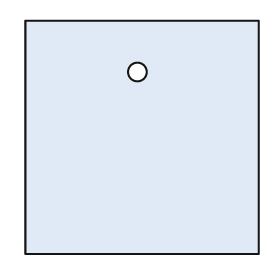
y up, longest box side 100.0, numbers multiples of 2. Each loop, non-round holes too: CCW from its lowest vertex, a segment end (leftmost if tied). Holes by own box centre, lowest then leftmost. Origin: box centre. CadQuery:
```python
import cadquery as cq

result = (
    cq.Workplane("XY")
    .moveTo(-50.0, -50.0)
    .lineTo(50.0, -50.0)
    .lineTo(50.0, 50.0)
    .lineTo(-50.0, 50.0)
    .close()
    .moveTo(-2.0, 28.0)
    .circle(4.0)
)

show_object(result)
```